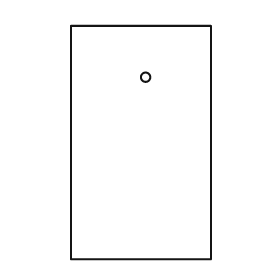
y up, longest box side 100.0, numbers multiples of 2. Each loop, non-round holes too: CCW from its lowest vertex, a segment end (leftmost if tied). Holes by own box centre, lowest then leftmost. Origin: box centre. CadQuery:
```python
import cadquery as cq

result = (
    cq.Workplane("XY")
    .moveTo(-30.0, -50.0)
    .lineTo(30.0, -50.0)
    .lineTo(30.0, 50.0)
    .lineTo(-30.0, 50.0)
    .close()
    .moveTo(2.0, 28.0)
    .circle(2.0)
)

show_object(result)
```